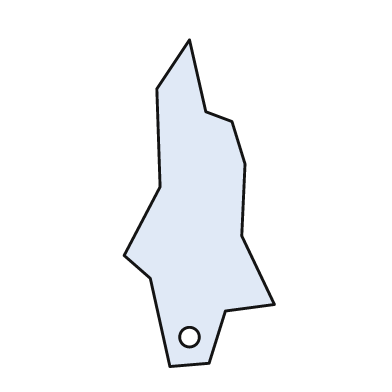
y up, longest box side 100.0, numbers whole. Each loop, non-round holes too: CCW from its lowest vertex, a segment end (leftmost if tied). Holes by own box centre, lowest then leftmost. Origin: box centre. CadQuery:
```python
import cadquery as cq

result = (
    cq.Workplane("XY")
    .moveTo(-9.0, -50.0)
    .lineTo(3.0, -49.0)
    .lineTo(8.0, -33.0)
    .lineTo(23.0, -31.0)
    .lineTo(13.0, -10.0)
    .lineTo(14.0, 12.0)
    .lineTo(10.0, 25.0)
    .lineTo(2.0, 28.0)
    .lineTo(-3.0, 50.0)
    .lineTo(-13.0, 35.0)
    .lineTo(-12.0, 5.0)
    .lineTo(-23.0, -16.0)
    .lineTo(-15.0, -23.0)
    .close()
    .moveTo(-3.0, -41.0)
    .circle(3.0)
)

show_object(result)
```